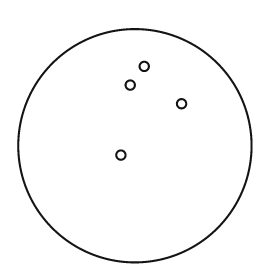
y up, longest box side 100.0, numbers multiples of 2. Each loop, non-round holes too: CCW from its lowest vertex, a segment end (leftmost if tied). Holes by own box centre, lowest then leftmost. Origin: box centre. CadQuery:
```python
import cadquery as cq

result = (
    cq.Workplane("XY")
    .moveTo(0.0, 0.0)
    .circle(50.0)
    .moveTo(-6.0, -4.0)
    .circle(2.0)
    .moveTo(20.0, 18.0)
    .circle(2.0)
    .moveTo(-2.0, 26.0)
    .circle(2.0)
    .moveTo(4.0, 34.0)
    .circle(2.0)
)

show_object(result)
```